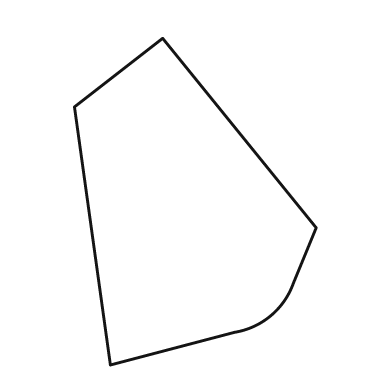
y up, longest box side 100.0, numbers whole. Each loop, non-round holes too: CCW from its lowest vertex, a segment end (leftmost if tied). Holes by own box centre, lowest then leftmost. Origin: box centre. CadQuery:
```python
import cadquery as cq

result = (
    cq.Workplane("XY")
    .moveTo(-26.0, -50.0)
    .lineTo(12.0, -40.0)
    .threePointArc((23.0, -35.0), (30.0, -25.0))
    .lineTo(37.0, -8.0)
    .lineTo(-10.0, 50.0)
    .lineTo(-37.0, 29.0)
    .close()
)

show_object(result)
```